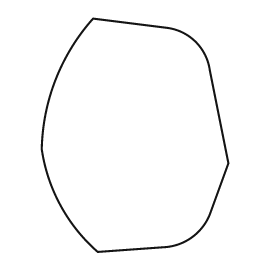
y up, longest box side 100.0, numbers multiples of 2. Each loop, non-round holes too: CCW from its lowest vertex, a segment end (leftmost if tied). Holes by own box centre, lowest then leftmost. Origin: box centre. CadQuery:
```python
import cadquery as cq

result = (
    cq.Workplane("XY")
    .moveTo(-16.0, -50.0)
    .lineTo(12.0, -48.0)
    .threePointArc((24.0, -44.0), (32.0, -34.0))
    .lineTo(40.0, -12.0)
    .lineTo(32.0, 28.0)
    .threePointArc((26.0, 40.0), (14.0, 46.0))
    .lineTo(-18.0, 50.0)
    .threePointArc((-34.0, 24.0), (-40.0, -6.0))
    .threePointArc((-32.0, -30.0), (-16.0, -50.0))
    .close()
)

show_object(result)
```